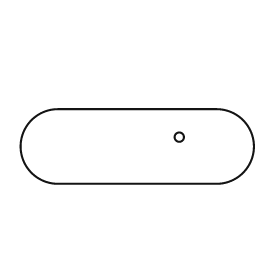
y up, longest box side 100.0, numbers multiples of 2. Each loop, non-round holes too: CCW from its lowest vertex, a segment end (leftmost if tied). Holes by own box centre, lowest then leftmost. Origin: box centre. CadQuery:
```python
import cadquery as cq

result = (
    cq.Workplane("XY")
    .moveTo(-34.0, -16.0)
    .lineTo(34.0, -16.0)
    .threePointArc((50.0, 0.0), (34.0, 16.0))
    .lineTo(-34.0, 16.0)
    .threePointArc((-50.0, 0.0), (-34.0, -16.0))
    .close()
    .moveTo(18.0, 4.0)
    .circle(2.0)
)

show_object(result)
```